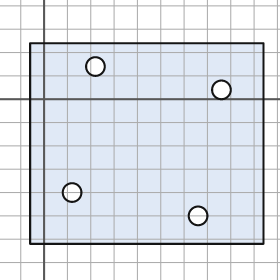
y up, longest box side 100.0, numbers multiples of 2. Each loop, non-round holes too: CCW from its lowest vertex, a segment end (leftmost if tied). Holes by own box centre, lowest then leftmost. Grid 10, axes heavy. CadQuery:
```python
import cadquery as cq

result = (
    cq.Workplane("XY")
    .moveTo(-6.0, -62.0)
    .lineTo(94.0, -62.0)
    .lineTo(94.0, 24.0)
    .lineTo(-6.0, 24.0)
    .close()
    .moveTo(66.0, -50.0)
    .circle(4.0)
    .moveTo(12.0, -40.0)
    .circle(4.0)
    .moveTo(76.0, 4.0)
    .circle(4.0)
    .moveTo(22.0, 14.0)
    .circle(4.0)
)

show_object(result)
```